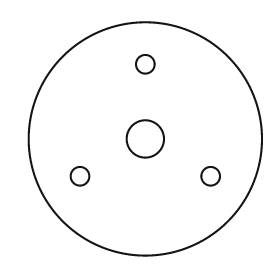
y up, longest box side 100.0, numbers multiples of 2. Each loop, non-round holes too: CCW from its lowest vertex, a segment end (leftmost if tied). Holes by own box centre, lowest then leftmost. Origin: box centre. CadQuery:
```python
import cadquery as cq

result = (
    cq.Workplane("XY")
    .moveTo(0.0, 0.0)
    .circle(50.0)
    .moveTo(-28.0, -16.0)
    .circle(4.0)
    .moveTo(28.0, -16.0)
    .circle(4.0)
    .moveTo(0.0, 0.0)
    .circle(8.0)
    .moveTo(0.0, 32.0)
    .circle(4.0)
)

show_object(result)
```